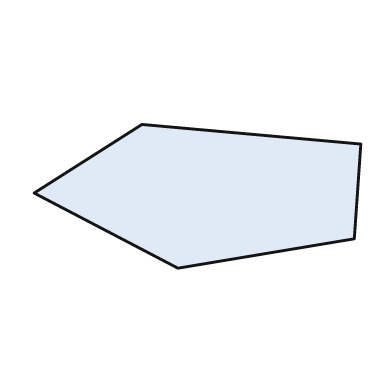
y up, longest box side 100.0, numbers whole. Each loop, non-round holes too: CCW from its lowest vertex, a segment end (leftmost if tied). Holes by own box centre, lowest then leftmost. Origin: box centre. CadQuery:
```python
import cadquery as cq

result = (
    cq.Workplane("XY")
    .moveTo(-6.0, -22.0)
    .lineTo(48.0, -13.0)
    .lineTo(50.0, 16.0)
    .lineTo(-17.0, 22.0)
    .lineTo(-50.0, 1.0)
    .close()
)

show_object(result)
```